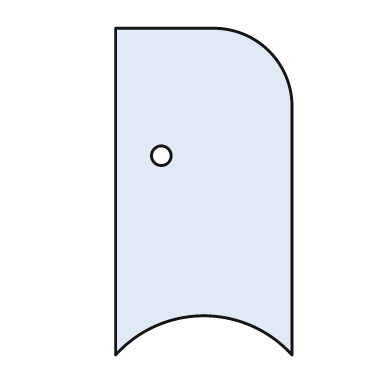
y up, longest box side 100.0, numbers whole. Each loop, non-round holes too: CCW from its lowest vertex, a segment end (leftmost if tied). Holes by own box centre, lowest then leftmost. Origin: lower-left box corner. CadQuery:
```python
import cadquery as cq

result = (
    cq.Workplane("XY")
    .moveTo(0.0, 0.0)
    .threePointArc((27.0, 12.0), (54.0, 0.0))
    .lineTo(54.0, 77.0)
    .threePointArc((47.0, 93.0), (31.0, 100.0))
    .lineTo(0.0, 100.0)
    .close()
    .moveTo(14.0, 61.0)
    .circle(3.0)
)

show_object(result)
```